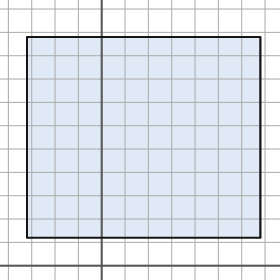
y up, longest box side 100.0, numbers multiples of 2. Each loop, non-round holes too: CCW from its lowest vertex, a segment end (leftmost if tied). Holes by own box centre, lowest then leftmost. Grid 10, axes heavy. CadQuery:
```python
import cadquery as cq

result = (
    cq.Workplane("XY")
    .moveTo(-32.0, 12.0)
    .lineTo(68.0, 12.0)
    .lineTo(68.0, 98.0)
    .lineTo(-32.0, 98.0)
    .close()
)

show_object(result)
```